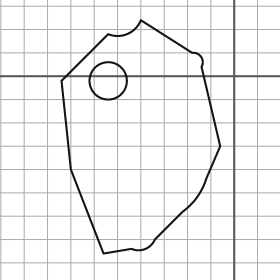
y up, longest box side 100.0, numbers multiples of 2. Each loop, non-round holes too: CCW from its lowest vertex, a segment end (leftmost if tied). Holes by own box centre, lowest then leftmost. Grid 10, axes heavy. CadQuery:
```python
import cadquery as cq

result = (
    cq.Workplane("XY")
    .moveTo(-56.0, -76.0)
    .lineTo(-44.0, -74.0)
    .threePointArc((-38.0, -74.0), (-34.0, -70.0))
    .lineTo(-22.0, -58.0)
    .threePointArc((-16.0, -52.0), (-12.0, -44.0))
    .lineTo(-6.0, -30.0)
    .lineTo(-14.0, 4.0)
    .threePointArc((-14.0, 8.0), (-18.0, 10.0))
    .lineTo(-40.0, 24.0)
    .threePointArc((-46.0, 18.0), (-54.0, 18.0))
    .lineTo(-74.0, -2.0)
    .lineTo(-70.0, -40.0)
    .close()
    .moveTo(-54.0, -2.0)
    .circle(8.0)
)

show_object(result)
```